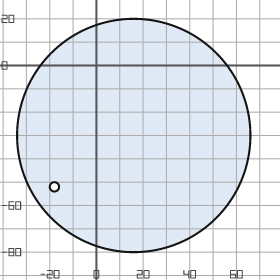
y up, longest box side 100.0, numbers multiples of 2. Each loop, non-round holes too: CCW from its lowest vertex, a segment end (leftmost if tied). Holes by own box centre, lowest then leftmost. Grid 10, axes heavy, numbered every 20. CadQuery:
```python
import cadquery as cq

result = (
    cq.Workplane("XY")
    .moveTo(16.0, -30.0)
    .circle(50.0)
    .moveTo(-18.0, -52.0)
    .circle(2.0)
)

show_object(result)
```